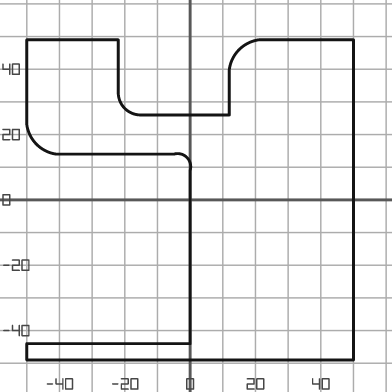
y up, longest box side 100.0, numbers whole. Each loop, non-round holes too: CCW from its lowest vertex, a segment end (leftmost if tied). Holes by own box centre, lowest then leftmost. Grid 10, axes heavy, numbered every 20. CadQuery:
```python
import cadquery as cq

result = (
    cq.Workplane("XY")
    .moveTo(-50.0, -49.0)
    .lineTo(50.0, -49.0)
    .lineTo(50.0, 49.0)
    .lineTo(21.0, 49.0)
    .threePointArc((15.0, 46.0), (12.0, 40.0))
    .lineTo(12.0, 26.0)
    .lineTo(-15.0, 26.0)
    .threePointArc((-20.0, 28.0), (-22.0, 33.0))
    .lineTo(-22.0, 49.0)
    .lineTo(-50.0, 49.0)
    .lineTo(-50.0, 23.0)
    .threePointArc((-47.0, 17.0), (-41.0, 14.0))
    .lineTo(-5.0, 14.0)
    .threePointArc((-1.0, 13.0), (0.0, 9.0))
    .lineTo(0.0, -44.0)
    .lineTo(-50.0, -44.0)
    .close()
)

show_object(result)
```